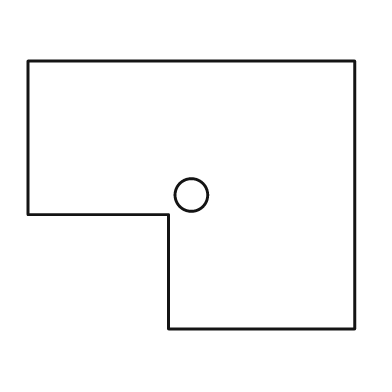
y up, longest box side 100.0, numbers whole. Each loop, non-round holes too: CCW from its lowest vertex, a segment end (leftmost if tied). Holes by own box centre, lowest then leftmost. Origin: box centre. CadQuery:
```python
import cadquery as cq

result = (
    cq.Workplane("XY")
    .moveTo(-7.0, -41.0)
    .lineTo(50.0, -41.0)
    .lineTo(50.0, 41.0)
    .lineTo(-50.0, 41.0)
    .lineTo(-50.0, -6.0)
    .lineTo(-7.0, -6.0)
    .close()
    .moveTo(0.0, 0.0)
    .circle(5.0)
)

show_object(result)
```